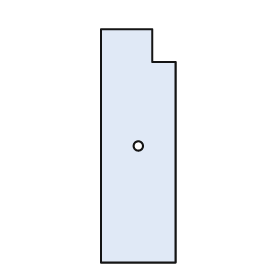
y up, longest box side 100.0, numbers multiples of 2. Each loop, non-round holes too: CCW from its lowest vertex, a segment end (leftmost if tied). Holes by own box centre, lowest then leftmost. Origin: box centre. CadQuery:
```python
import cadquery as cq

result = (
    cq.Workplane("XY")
    .moveTo(-16.0, -50.0)
    .lineTo(16.0, -50.0)
    .lineTo(16.0, 36.0)
    .lineTo(6.0, 36.0)
    .lineTo(6.0, 50.0)
    .lineTo(-16.0, 50.0)
    .close()
    .moveTo(0.0, 0.0)
    .circle(2.0)
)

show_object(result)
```